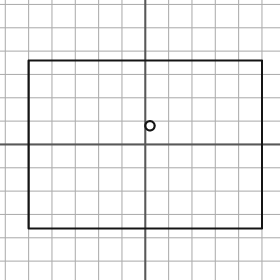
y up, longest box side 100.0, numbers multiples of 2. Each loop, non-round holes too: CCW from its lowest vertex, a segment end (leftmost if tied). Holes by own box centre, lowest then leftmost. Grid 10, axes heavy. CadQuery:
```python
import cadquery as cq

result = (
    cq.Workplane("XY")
    .moveTo(-50.0, -36.0)
    .lineTo(50.0, -36.0)
    .lineTo(50.0, 36.0)
    .lineTo(-50.0, 36.0)
    .close()
    .moveTo(2.0, 8.0)
    .circle(2.0)
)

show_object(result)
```